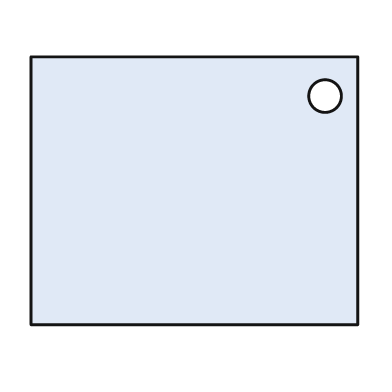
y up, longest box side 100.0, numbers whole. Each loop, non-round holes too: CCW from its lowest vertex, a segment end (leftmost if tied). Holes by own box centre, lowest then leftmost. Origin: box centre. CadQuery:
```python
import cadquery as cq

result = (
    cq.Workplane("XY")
    .moveTo(-50.0, -41.0)
    .lineTo(50.0, -41.0)
    .lineTo(50.0, 41.0)
    .lineTo(-50.0, 41.0)
    .close()
    .moveTo(40.0, 29.0)
    .circle(5.0)
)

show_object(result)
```